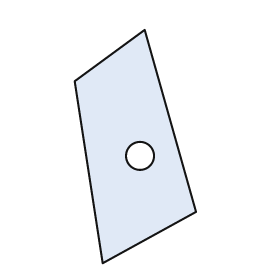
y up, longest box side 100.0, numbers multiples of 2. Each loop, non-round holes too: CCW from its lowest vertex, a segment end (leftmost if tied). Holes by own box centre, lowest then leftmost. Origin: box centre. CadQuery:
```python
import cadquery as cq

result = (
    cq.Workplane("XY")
    .moveTo(-14.0, -50.0)
    .lineTo(26.0, -28.0)
    .lineTo(4.0, 50.0)
    .lineTo(-26.0, 28.0)
    .close()
    .moveTo(2.0, -4.0)
    .circle(6.0)
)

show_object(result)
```